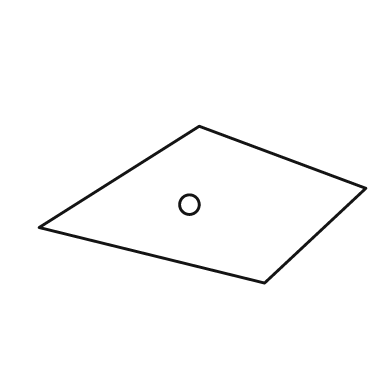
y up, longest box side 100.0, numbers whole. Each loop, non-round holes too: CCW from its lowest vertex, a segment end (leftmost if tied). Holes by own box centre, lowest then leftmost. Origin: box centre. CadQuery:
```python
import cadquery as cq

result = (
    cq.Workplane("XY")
    .moveTo(19.0, -24.0)
    .lineTo(50.0, 5.0)
    .lineTo(-1.0, 24.0)
    .lineTo(-50.0, -7.0)
    .close()
    .moveTo(-4.0, 0.0)
    .circle(3.0)
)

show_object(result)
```